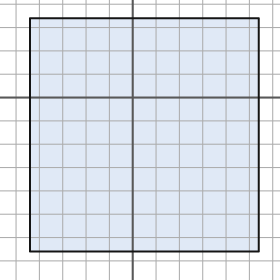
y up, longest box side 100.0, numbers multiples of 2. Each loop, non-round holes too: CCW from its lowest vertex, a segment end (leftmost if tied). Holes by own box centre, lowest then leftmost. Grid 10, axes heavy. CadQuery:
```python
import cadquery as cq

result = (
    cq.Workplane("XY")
    .moveTo(-44.0, -66.0)
    .lineTo(54.0, -66.0)
    .lineTo(54.0, 34.0)
    .lineTo(-44.0, 34.0)
    .close()
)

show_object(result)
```